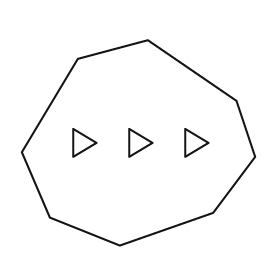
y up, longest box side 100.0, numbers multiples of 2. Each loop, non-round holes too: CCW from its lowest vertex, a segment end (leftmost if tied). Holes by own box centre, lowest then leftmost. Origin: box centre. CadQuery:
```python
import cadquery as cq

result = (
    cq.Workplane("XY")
    .moveTo(-8.0, -44.0)
    .lineTo(32.0, -30.0)
    .lineTo(50.0, -6.0)
    .lineTo(42.0, 18.0)
    .lineTo(4.0, 44.0)
    .lineTo(-26.0, 36.0)
    .lineTo(-50.0, -4.0)
    .lineTo(-38.0, -32.0)
    .close()
    .moveTo(-28.0, -6.0)
    .lineTo(-18.0, 0.0)
    .lineTo(-28.0, 6.0)
    .close()
    .moveTo(-4.0, -6.0)
    .lineTo(6.0, 0.0)
    .lineTo(-4.0, 6.0)
    .close()
    .moveTo(20.0, -6.0)
    .lineTo(30.0, 0.0)
    .lineTo(20.0, 6.0)
    .close()
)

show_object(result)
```